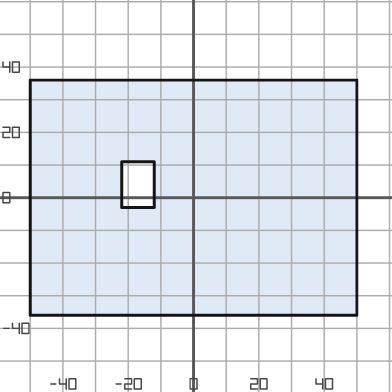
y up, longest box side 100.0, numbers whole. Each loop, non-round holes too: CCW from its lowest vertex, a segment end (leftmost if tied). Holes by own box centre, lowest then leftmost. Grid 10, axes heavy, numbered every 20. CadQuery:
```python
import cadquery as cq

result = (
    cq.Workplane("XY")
    .moveTo(-50.0, -36.0)
    .lineTo(50.0, -36.0)
    .lineTo(50.0, 36.0)
    .lineTo(-50.0, 36.0)
    .close()
    .moveTo(-22.0, -3.0)
    .lineTo(-12.0, -3.0)
    .lineTo(-12.0, 11.0)
    .lineTo(-22.0, 11.0)
    .close()
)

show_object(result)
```